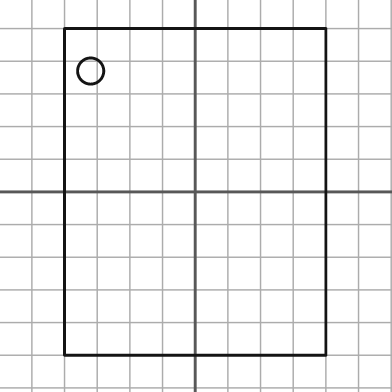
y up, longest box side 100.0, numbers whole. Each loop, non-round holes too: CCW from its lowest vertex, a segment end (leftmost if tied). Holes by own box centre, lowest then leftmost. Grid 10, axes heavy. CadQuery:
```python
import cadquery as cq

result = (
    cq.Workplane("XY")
    .moveTo(-40.0, -50.0)
    .lineTo(40.0, -50.0)
    .lineTo(40.0, 50.0)
    .lineTo(-40.0, 50.0)
    .close()
    .moveTo(-32.0, 37.0)
    .circle(4.0)
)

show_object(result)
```